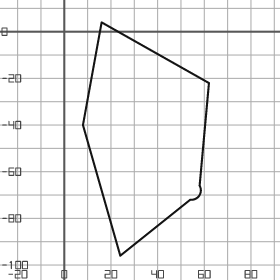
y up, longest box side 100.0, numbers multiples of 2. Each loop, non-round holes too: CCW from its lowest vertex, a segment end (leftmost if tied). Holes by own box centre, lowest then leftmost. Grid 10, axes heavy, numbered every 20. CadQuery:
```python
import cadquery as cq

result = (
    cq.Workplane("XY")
    .moveTo(24.0, -96.0)
    .lineTo(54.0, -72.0)
    .threePointArc((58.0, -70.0), (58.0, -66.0))
    .lineTo(62.0, -22.0)
    .lineTo(16.0, 4.0)
    .lineTo(8.0, -40.0)
    .close()
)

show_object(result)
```